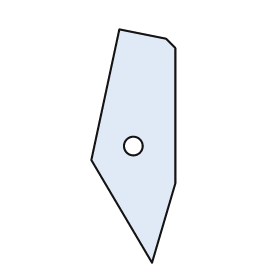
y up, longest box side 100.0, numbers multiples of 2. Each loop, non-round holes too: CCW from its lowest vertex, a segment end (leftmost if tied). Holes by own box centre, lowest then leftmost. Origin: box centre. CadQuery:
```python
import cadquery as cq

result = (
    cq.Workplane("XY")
    .moveTo(8.0, -50.0)
    .lineTo(18.0, -16.0)
    .lineTo(18.0, 42.0)
    .lineTo(14.0, 46.0)
    .lineTo(-6.0, 50.0)
    .lineTo(-18.0, -6.0)
    .close()
    .moveTo(0.0, 0.0)
    .circle(4.0)
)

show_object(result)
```